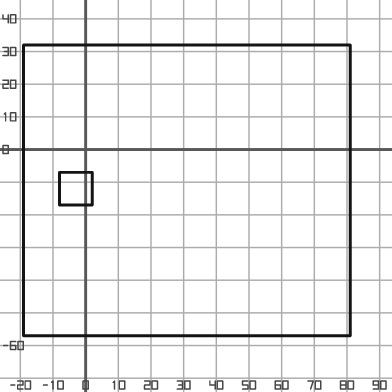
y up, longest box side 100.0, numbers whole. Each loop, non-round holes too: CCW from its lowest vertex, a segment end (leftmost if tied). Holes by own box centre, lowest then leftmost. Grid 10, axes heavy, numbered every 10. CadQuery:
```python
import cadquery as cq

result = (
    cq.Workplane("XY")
    .moveTo(-19.0, -57.0)
    .lineTo(81.0, -57.0)
    .lineTo(81.0, 32.0)
    .lineTo(-19.0, 32.0)
    .close()
    .moveTo(-8.0, -17.0)
    .lineTo(2.0, -17.0)
    .lineTo(2.0, -7.0)
    .lineTo(-8.0, -7.0)
    .close()
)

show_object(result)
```